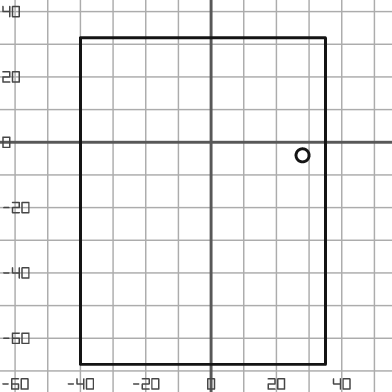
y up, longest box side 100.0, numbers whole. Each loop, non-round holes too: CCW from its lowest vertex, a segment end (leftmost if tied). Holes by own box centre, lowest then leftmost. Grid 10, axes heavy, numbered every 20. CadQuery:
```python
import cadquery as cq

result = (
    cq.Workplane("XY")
    .moveTo(-40.0, -68.0)
    .lineTo(35.0, -68.0)
    .lineTo(35.0, 32.0)
    .lineTo(-40.0, 32.0)
    .close()
    .moveTo(28.0, -4.0)
    .circle(2.0)
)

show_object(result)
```